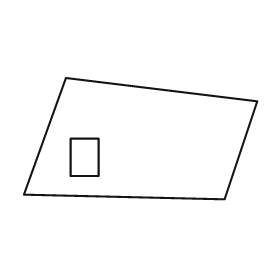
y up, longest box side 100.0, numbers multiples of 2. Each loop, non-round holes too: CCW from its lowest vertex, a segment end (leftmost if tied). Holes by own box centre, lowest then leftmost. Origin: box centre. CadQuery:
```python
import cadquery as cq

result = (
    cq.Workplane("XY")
    .moveTo(36.0, -26.0)
    .lineTo(50.0, 16.0)
    .lineTo(-32.0, 26.0)
    .lineTo(-50.0, -24.0)
    .close()
    .moveTo(-30.0, -16.0)
    .lineTo(-18.0, -16.0)
    .lineTo(-18.0, 0.0)
    .lineTo(-30.0, 0.0)
    .close()
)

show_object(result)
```